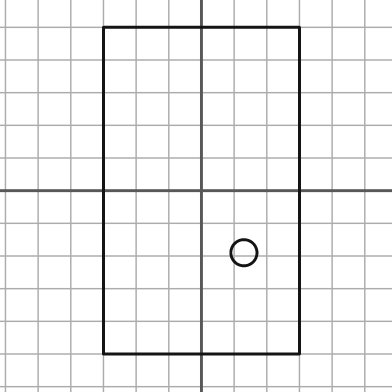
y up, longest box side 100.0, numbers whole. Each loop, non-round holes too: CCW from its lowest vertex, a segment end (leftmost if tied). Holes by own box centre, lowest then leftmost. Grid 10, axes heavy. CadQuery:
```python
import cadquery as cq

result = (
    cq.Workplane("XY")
    .moveTo(-30.0, -50.0)
    .lineTo(30.0, -50.0)
    .lineTo(30.0, 50.0)
    .lineTo(-30.0, 50.0)
    .close()
    .moveTo(13.0, -19.0)
    .circle(4.0)
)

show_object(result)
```